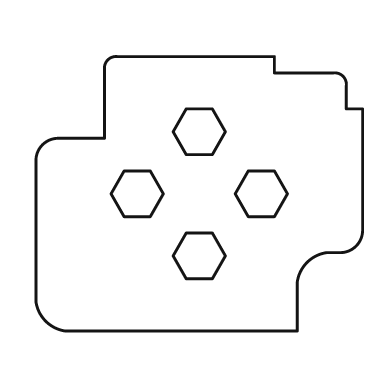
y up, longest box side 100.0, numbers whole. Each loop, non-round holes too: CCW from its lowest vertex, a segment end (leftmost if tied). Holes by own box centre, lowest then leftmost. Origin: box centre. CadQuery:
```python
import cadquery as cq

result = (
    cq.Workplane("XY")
    .moveTo(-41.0, -42.0)
    .lineTo(30.0, -42.0)
    .lineTo(30.0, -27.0)
    .threePointArc((33.0, -21.0), (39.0, -18.0))
    .lineTo(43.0, -18.0)
    .threePointArc((48.0, -16.0), (50.0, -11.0))
    .lineTo(50.0, 26.0)
    .lineTo(45.0, 26.0)
    .lineTo(45.0, 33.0)
    .threePointArc((44.0, 36.0), (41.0, 37.0))
    .lineTo(23.0, 37.0)
    .lineTo(23.0, 42.0)
    .lineTo(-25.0, 42.0)
    .threePointArc((-28.0, 41.0), (-29.0, 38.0))
    .lineTo(-29.0, 17.0)
    .lineTo(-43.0, 17.0)
    .threePointArc((-48.0, 15.0), (-50.0, 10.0))
    .lineTo(-50.0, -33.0)
    .threePointArc((-47.0, -39.0), (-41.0, -42.0))
    .close()
    .moveTo(-4.0, -26.0)
    .lineTo(4.0, -26.0)
    .lineTo(8.0, -19.0)
    .lineTo(4.0, -12.0)
    .lineTo(-4.0, -12.0)
    .lineTo(-8.0, -19.0)
    .close()
    .moveTo(-23.0, -7.0)
    .lineTo(-15.0, -7.0)
    .lineTo(-11.0, 0.0)
    .lineTo(-15.0, 7.0)
    .lineTo(-23.0, 7.0)
    .lineTo(-27.0, 0.0)
    .close()
    .moveTo(15.0, -7.0)
    .lineTo(23.0, -7.0)
    .lineTo(27.0, 0.0)
    .lineTo(23.0, 7.0)
    .lineTo(15.0, 7.0)
    .lineTo(11.0, 0.0)
    .close()
    .moveTo(-4.0, 12.0)
    .lineTo(4.0, 12.0)
    .lineTo(8.0, 19.0)
    .lineTo(4.0, 26.0)
    .lineTo(-4.0, 26.0)
    .lineTo(-8.0, 19.0)
    .close()
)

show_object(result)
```